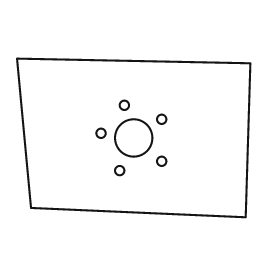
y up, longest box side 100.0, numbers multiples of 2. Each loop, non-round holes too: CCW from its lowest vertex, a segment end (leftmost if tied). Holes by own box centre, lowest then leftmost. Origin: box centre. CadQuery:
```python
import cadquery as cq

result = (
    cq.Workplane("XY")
    .moveTo(48.0, -34.0)
    .lineTo(50.0, 32.0)
    .lineTo(-50.0, 34.0)
    .lineTo(-44.0, -30.0)
    .close()
    .moveTo(-6.0, -14.0)
    .circle(2.0)
    .moveTo(12.0, -10.0)
    .circle(2.0)
    .moveTo(0.0, 0.0)
    .circle(8.0)
    .moveTo(-14.0, 2.0)
    .circle(2.0)
    .moveTo(12.0, 8.0)
    .circle(2.0)
    .moveTo(-4.0, 14.0)
    .circle(2.0)
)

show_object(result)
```